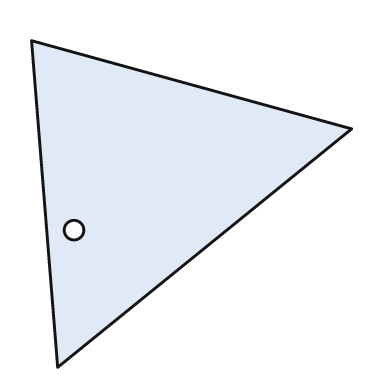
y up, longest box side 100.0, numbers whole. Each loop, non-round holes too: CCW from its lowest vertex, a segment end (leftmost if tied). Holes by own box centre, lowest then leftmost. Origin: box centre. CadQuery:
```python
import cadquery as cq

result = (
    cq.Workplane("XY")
    .moveTo(-41.0, -50.0)
    .lineTo(49.0, 23.0)
    .lineTo(-49.0, 50.0)
    .close()
    .moveTo(-36.0, -8.0)
    .circle(3.0)
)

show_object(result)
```